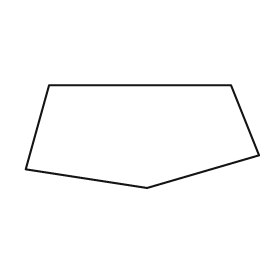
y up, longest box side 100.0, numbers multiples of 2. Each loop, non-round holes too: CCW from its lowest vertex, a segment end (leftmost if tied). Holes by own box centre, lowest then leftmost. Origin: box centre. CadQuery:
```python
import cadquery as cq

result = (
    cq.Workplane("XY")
    .moveTo(2.0, -22.0)
    .lineTo(50.0, -8.0)
    .lineTo(38.0, 22.0)
    .lineTo(-40.0, 22.0)
    .lineTo(-50.0, -14.0)
    .close()
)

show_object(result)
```